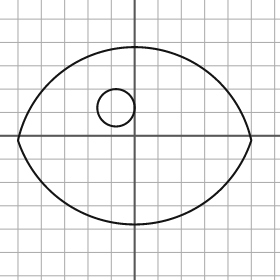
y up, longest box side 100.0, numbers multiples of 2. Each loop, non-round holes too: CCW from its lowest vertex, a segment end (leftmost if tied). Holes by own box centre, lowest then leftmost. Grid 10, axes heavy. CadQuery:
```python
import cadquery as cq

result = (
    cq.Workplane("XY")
    .moveTo(-50.0, -2.0)
    .threePointArc((0.0, -38.0), (50.0, -2.0))
    .threePointArc((0.0, 38.0), (-50.0, -2.0))
    .close()
    .moveTo(-8.0, 12.0)
    .circle(8.0)
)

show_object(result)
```